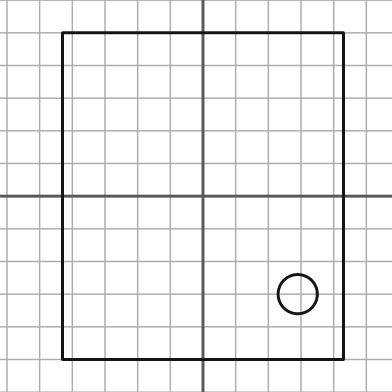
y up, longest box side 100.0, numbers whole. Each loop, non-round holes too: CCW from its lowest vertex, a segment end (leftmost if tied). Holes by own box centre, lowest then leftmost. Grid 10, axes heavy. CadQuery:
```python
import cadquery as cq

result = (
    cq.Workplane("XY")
    .moveTo(-43.0, -50.0)
    .lineTo(43.0, -50.0)
    .lineTo(43.0, 50.0)
    .lineTo(-43.0, 50.0)
    .close()
    .moveTo(29.0, -30.0)
    .circle(6.0)
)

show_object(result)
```